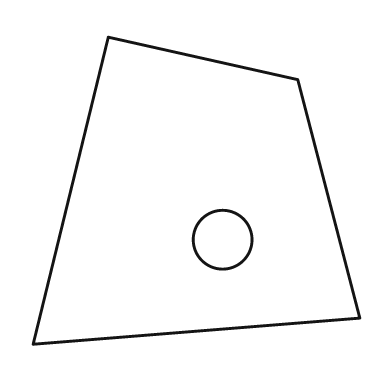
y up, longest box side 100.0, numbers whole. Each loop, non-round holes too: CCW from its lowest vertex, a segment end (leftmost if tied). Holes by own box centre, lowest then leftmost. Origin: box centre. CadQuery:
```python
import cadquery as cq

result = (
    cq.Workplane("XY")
    .moveTo(-50.0, -47.0)
    .lineTo(50.0, -39.0)
    .lineTo(31.0, 34.0)
    .lineTo(-27.0, 47.0)
    .close()
    .moveTo(8.0, -15.0)
    .circle(9.0)
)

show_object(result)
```